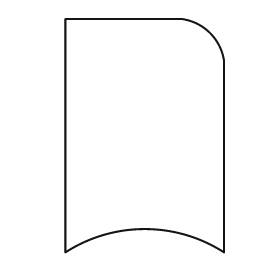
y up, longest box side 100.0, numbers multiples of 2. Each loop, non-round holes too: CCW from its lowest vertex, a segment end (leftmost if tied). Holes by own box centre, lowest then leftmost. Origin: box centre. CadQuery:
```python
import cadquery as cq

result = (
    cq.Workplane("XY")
    .moveTo(-34.0, -50.0)
    .threePointArc((0.0, -40.0), (34.0, -50.0))
    .lineTo(34.0, 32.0)
    .threePointArc((28.0, 44.0), (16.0, 50.0))
    .lineTo(-34.0, 50.0)
    .close()
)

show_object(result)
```